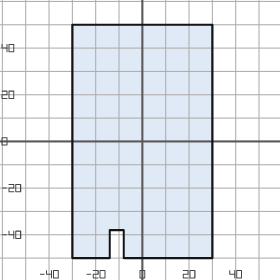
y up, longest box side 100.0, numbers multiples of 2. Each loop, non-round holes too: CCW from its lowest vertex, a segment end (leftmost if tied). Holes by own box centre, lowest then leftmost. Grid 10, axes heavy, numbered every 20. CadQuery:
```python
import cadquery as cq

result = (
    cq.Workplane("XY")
    .moveTo(-30.0, -50.0)
    .lineTo(-14.0, -50.0)
    .lineTo(-14.0, -38.0)
    .lineTo(-8.0, -38.0)
    .lineTo(-8.0, -50.0)
    .lineTo(30.0, -50.0)
    .lineTo(30.0, 50.0)
    .lineTo(-30.0, 50.0)
    .close()
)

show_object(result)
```